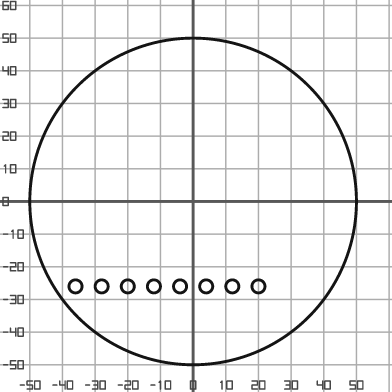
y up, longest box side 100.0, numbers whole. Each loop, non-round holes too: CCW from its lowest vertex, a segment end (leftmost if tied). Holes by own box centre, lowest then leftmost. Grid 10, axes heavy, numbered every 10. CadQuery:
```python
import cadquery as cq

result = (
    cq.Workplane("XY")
    .moveTo(0.0, 0.0)
    .circle(50.0)
    .moveTo(-36.0, -26.0)
    .circle(2.0)
    .moveTo(-28.0, -26.0)
    .circle(2.0)
    .moveTo(-20.0, -26.0)
    .circle(2.0)
    .moveTo(-12.0, -26.0)
    .circle(2.0)
    .moveTo(-4.0, -26.0)
    .circle(2.0)
    .moveTo(4.0, -26.0)
    .circle(2.0)
    .moveTo(12.0, -26.0)
    .circle(2.0)
    .moveTo(20.0, -26.0)
    .circle(2.0)
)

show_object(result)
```